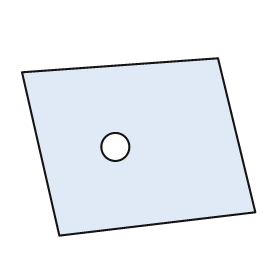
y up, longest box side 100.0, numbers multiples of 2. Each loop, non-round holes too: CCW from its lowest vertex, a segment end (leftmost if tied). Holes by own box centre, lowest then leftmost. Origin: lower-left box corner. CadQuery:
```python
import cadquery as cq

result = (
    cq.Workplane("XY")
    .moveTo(16.0, 0.0)
    .lineTo(100.0, 10.0)
    .lineTo(84.0, 76.0)
    .lineTo(0.0, 70.0)
    .close()
    .moveTo(40.0, 38.0)
    .circle(6.0)
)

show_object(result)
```